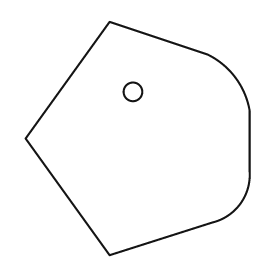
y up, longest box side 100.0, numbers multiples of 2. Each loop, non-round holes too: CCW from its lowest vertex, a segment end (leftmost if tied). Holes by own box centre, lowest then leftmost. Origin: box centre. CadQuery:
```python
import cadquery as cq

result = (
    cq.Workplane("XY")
    .moveTo(-12.0, -50.0)
    .lineTo(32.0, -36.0)
    .threePointArc((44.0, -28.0), (48.0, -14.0))
    .lineTo(48.0, 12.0)
    .threePointArc((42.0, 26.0), (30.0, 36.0))
    .lineTo(-12.0, 50.0)
    .lineTo(-48.0, 0.0)
    .close()
    .moveTo(-2.0, 20.0)
    .circle(4.0)
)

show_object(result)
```